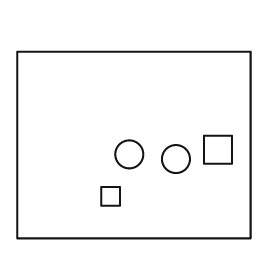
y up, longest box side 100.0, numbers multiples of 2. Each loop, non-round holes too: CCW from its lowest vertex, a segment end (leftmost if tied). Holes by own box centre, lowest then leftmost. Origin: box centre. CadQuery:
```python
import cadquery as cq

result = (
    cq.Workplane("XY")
    .moveTo(-50.0, -40.0)
    .lineTo(50.0, -40.0)
    .lineTo(50.0, 40.0)
    .lineTo(-50.0, 40.0)
    .close()
    .moveTo(-14.0, -26.0)
    .lineTo(-6.0, -26.0)
    .lineTo(-6.0, -18.0)
    .lineTo(-14.0, -18.0)
    .close()
    .moveTo(18.0, -6.0)
    .circle(6.0)
    .moveTo(-2.0, -4.0)
    .circle(6.0)
    .moveTo(30.0, -8.0)
    .lineTo(42.0, -8.0)
    .lineTo(42.0, 4.0)
    .lineTo(30.0, 4.0)
    .close()
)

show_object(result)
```